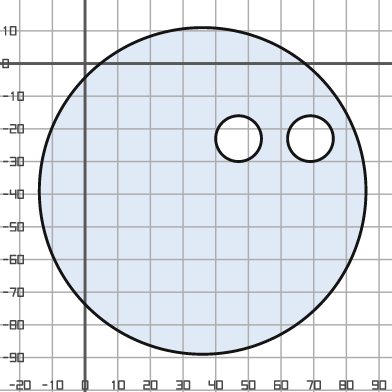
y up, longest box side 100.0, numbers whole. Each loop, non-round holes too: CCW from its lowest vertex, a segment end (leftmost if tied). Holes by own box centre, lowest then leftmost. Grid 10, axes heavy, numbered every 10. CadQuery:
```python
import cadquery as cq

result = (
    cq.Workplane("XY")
    .moveTo(36.0, -39.0)
    .circle(50.0)
    .moveTo(47.0, -23.0)
    .circle(7.0)
    .moveTo(69.0, -23.0)
    .circle(7.0)
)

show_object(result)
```